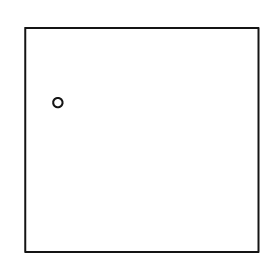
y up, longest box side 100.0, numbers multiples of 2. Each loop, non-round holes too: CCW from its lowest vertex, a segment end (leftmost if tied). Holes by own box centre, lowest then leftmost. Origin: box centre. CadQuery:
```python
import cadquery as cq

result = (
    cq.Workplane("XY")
    .moveTo(-50.0, -48.0)
    .lineTo(50.0, -48.0)
    .lineTo(50.0, 48.0)
    .lineTo(-50.0, 48.0)
    .close()
    .moveTo(-36.0, 16.0)
    .circle(2.0)
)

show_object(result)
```